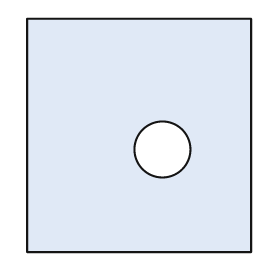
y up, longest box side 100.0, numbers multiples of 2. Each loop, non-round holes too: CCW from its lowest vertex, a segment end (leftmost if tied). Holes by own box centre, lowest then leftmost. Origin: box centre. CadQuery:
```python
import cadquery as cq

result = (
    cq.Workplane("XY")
    .moveTo(-48.0, -50.0)
    .lineTo(48.0, -50.0)
    .lineTo(48.0, 50.0)
    .lineTo(-48.0, 50.0)
    .close()
    .moveTo(10.0, -6.0)
    .circle(12.0)
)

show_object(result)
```